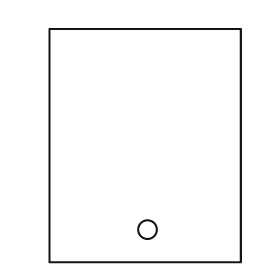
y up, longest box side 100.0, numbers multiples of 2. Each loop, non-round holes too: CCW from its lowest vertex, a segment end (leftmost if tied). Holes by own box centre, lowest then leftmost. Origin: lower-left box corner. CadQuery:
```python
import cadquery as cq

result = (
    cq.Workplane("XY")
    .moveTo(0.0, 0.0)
    .lineTo(82.0, 0.0)
    .lineTo(82.0, 100.0)
    .lineTo(0.0, 100.0)
    .close()
    .moveTo(42.0, 14.0)
    .circle(4.0)
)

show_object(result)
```